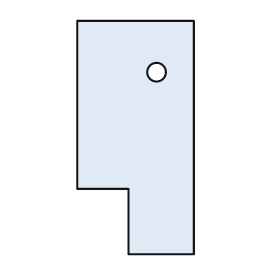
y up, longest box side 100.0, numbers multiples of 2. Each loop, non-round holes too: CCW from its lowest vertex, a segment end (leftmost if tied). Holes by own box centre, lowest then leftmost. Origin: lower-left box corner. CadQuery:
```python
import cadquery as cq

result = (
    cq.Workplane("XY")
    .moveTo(22.0, 0.0)
    .lineTo(50.0, 0.0)
    .lineTo(50.0, 100.0)
    .lineTo(0.0, 100.0)
    .lineTo(0.0, 28.0)
    .lineTo(22.0, 28.0)
    .close()
    .moveTo(34.0, 78.0)
    .circle(4.0)
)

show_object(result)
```